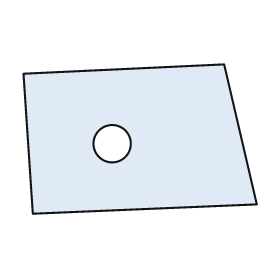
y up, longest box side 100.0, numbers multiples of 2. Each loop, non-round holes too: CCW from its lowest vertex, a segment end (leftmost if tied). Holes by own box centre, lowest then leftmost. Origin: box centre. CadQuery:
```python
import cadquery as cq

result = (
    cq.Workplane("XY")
    .moveTo(-46.0, -32.0)
    .lineTo(50.0, -28.0)
    .lineTo(36.0, 32.0)
    .lineTo(-50.0, 28.0)
    .close()
    .moveTo(-12.0, -2.0)
    .circle(8.0)
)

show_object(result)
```